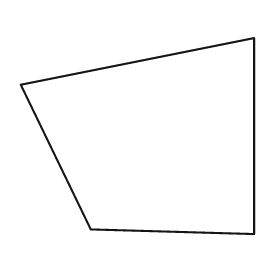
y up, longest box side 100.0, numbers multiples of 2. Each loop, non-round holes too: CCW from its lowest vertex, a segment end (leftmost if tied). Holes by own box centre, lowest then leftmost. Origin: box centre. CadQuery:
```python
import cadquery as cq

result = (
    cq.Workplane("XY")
    .moveTo(50.0, -42.0)
    .lineTo(50.0, 42.0)
    .lineTo(-50.0, 22.0)
    .lineTo(-20.0, -40.0)
    .close()
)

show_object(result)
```